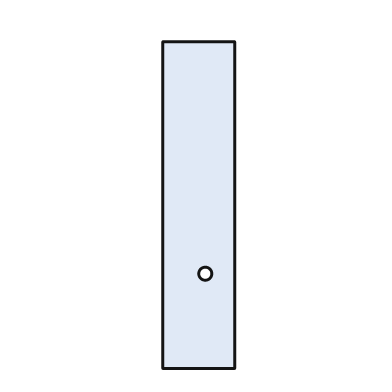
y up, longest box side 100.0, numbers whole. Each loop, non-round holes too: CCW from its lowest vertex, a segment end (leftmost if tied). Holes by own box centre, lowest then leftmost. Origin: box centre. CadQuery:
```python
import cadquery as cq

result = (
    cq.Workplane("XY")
    .moveTo(-11.0, -50.0)
    .lineTo(11.0, -50.0)
    .lineTo(11.0, 50.0)
    .lineTo(-11.0, 50.0)
    .close()
    .moveTo(2.0, -21.0)
    .circle(2.0)
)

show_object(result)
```